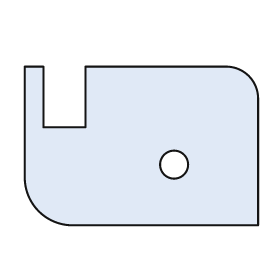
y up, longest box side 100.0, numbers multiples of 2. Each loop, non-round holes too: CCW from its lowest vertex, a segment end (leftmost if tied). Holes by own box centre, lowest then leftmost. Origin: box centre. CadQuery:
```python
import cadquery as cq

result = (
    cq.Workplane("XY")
    .moveTo(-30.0, -34.0)
    .lineTo(50.0, -34.0)
    .lineTo(50.0, 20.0)
    .threePointArc((46.0, 30.0), (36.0, 34.0))
    .lineTo(-24.0, 34.0)
    .lineTo(-24.0, 8.0)
    .lineTo(-42.0, 8.0)
    .lineTo(-42.0, 34.0)
    .lineTo(-50.0, 34.0)
    .lineTo(-50.0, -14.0)
    .threePointArc((-44.0, -28.0), (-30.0, -34.0))
    .close()
    .moveTo(14.0, -8.0)
    .circle(6.0)
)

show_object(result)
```